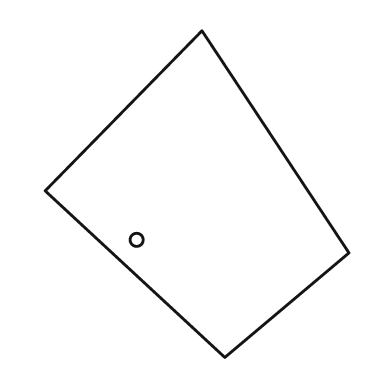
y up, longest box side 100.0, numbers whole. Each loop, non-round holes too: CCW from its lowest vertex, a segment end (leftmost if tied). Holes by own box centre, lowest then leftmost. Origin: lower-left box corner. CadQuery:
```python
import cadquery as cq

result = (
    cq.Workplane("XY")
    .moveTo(55.0, 0.0)
    .lineTo(93.0, 32.0)
    .lineTo(48.0, 100.0)
    .lineTo(0.0, 51.0)
    .close()
    .moveTo(28.0, 36.0)
    .circle(2.0)
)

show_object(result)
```